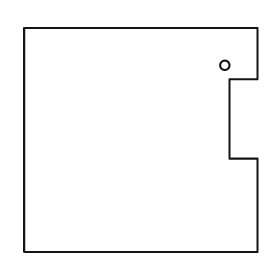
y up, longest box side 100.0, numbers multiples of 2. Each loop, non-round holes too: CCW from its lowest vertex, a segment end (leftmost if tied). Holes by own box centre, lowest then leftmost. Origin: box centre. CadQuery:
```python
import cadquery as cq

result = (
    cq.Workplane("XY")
    .moveTo(-50.0, -48.0)
    .lineTo(50.0, -48.0)
    .lineTo(50.0, -8.0)
    .lineTo(38.0, -8.0)
    .lineTo(38.0, 26.0)
    .lineTo(50.0, 26.0)
    .lineTo(50.0, 48.0)
    .lineTo(-50.0, 48.0)
    .close()
    .moveTo(36.0, 32.0)
    .circle(2.0)
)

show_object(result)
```